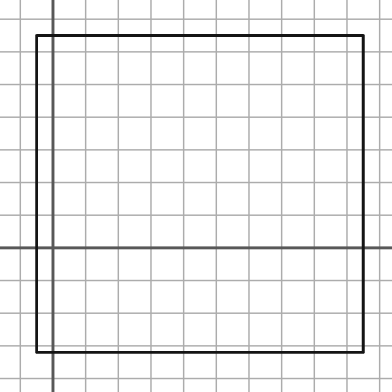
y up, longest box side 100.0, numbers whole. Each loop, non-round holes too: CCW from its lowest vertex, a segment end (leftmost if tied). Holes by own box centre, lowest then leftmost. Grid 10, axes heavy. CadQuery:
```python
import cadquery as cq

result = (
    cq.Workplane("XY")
    .moveTo(-5.0, -32.0)
    .lineTo(95.0, -32.0)
    .lineTo(95.0, 65.0)
    .lineTo(-5.0, 65.0)
    .close()
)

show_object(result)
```